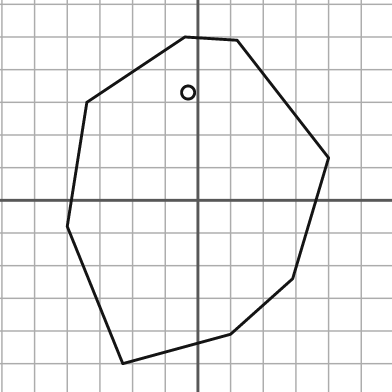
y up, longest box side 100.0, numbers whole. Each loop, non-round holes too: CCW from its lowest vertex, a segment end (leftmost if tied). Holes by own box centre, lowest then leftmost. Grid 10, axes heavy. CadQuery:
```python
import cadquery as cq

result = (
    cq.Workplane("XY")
    .moveTo(-23.0, -50.0)
    .lineTo(10.0, -41.0)
    .lineTo(29.0, -24.0)
    .lineTo(40.0, 13.0)
    .lineTo(12.0, 49.0)
    .lineTo(-4.0, 50.0)
    .lineTo(-34.0, 30.0)
    .lineTo(-40.0, -8.0)
    .close()
    .moveTo(-3.0, 33.0)
    .circle(2.0)
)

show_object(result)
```